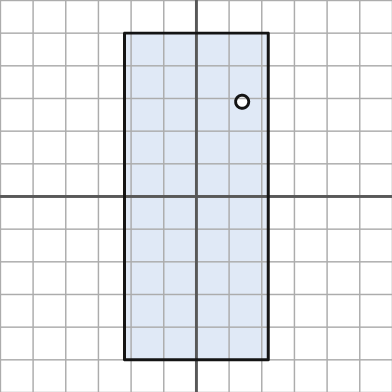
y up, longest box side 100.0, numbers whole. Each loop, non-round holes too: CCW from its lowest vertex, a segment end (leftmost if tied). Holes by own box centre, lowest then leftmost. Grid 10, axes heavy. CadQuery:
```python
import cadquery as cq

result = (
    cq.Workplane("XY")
    .moveTo(-22.0, -50.0)
    .lineTo(22.0, -50.0)
    .lineTo(22.0, 50.0)
    .lineTo(-22.0, 50.0)
    .close()
    .moveTo(14.0, 29.0)
    .circle(2.0)
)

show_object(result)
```